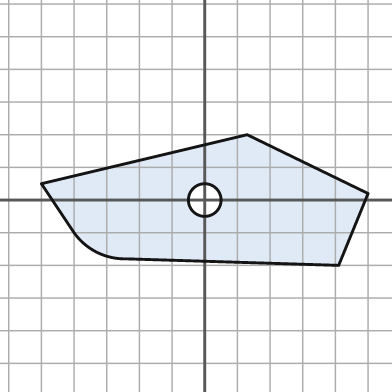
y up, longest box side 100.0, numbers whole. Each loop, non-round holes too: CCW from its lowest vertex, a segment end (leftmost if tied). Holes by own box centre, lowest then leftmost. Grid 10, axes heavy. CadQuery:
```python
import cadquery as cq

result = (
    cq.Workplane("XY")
    .moveTo(41.0, -20.0)
    .lineTo(50.0, 2.0)
    .lineTo(13.0, 20.0)
    .lineTo(-50.0, 5.0)
    .lineTo(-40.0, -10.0)
    .threePointArc((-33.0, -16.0), (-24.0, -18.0))
    .close()
    .moveTo(0.0, 0.0)
    .circle(5.0)
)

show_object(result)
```